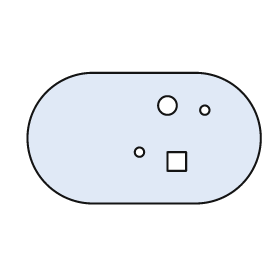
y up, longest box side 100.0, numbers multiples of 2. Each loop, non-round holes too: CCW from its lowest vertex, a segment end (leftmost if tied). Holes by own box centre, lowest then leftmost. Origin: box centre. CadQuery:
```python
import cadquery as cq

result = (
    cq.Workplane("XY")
    .moveTo(-22.0, -28.0)
    .lineTo(22.0, -28.0)
    .threePointArc((50.0, 0.0), (22.0, 28.0))
    .lineTo(-22.0, 28.0)
    .threePointArc((-50.0, 0.0), (-22.0, -28.0))
    .close()
    .moveTo(10.0, -14.0)
    .lineTo(18.0, -14.0)
    .lineTo(18.0, -6.0)
    .lineTo(10.0, -6.0)
    .close()
    .moveTo(-2.0, -6.0)
    .circle(2.0)
    .moveTo(26.0, 12.0)
    .circle(2.0)
    .moveTo(10.0, 14.0)
    .circle(4.0)
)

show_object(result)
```